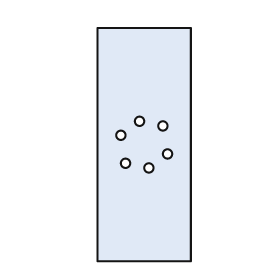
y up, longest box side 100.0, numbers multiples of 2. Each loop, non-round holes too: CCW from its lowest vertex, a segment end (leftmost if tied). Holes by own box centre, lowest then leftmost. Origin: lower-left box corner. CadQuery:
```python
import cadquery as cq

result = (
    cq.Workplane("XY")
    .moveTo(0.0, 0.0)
    .lineTo(40.0, 0.0)
    .lineTo(40.0, 100.0)
    .lineTo(0.0, 100.0)
    .close()
    .moveTo(22.0, 40.0)
    .circle(2.0)
    .moveTo(12.0, 42.0)
    .circle(2.0)
    .moveTo(30.0, 46.0)
    .circle(2.0)
    .moveTo(10.0, 54.0)
    .circle(2.0)
    .moveTo(28.0, 58.0)
    .circle(2.0)
    .moveTo(18.0, 60.0)
    .circle(2.0)
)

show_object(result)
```